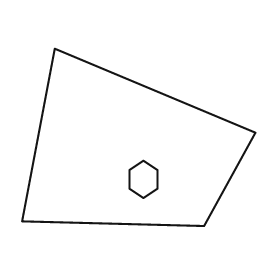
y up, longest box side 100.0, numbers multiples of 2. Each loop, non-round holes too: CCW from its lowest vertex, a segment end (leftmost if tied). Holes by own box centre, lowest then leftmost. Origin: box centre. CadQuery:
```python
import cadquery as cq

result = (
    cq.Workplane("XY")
    .moveTo(28.0, -38.0)
    .lineTo(50.0, 2.0)
    .lineTo(-36.0, 38.0)
    .lineTo(-50.0, -36.0)
    .close()
    .moveTo(2.0, -26.0)
    .lineTo(8.0, -22.0)
    .lineTo(8.0, -14.0)
    .lineTo(2.0, -10.0)
    .lineTo(-4.0, -14.0)
    .lineTo(-4.0, -22.0)
    .close()
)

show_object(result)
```